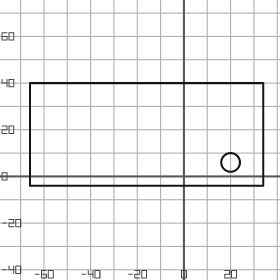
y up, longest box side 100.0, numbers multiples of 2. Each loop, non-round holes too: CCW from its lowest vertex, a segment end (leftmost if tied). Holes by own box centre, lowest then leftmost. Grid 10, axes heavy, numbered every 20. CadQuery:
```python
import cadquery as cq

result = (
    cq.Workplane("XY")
    .moveTo(-66.0, -4.0)
    .lineTo(34.0, -4.0)
    .lineTo(34.0, 40.0)
    .lineTo(-66.0, 40.0)
    .close()
    .moveTo(20.0, 6.0)
    .circle(4.0)
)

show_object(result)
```